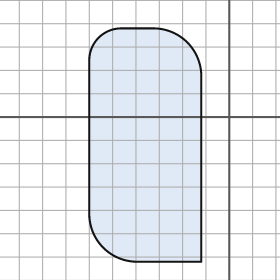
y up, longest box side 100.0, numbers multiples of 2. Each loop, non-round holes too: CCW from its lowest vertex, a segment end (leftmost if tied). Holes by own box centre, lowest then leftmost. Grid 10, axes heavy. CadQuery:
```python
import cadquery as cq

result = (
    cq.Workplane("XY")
    .moveTo(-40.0, -62.0)
    .lineTo(-12.0, -62.0)
    .lineTo(-12.0, 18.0)
    .threePointArc((-18.0, 32.0), (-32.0, 38.0))
    .lineTo(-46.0, 38.0)
    .threePointArc((-56.0, 34.0), (-60.0, 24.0))
    .lineTo(-60.0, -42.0)
    .threePointArc((-54.0, -56.0), (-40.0, -62.0))
    .close()
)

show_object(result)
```